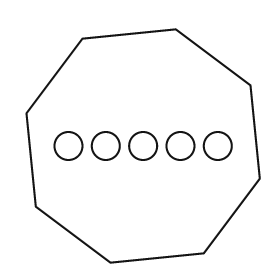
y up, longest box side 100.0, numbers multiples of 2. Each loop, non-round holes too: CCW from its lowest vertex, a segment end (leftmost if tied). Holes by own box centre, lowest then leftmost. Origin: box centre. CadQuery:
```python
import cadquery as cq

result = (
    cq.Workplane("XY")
    .moveTo(-14.0, -50.0)
    .lineTo(26.0, -46.0)
    .lineTo(50.0, -14.0)
    .lineTo(46.0, 26.0)
    .lineTo(14.0, 50.0)
    .lineTo(-26.0, 46.0)
    .lineTo(-50.0, 14.0)
    .lineTo(-46.0, -26.0)
    .close()
    .moveTo(-32.0, 0.0)
    .circle(6.0)
    .moveTo(-16.0, 0.0)
    .circle(6.0)
    .moveTo(0.0, 0.0)
    .circle(6.0)
    .moveTo(16.0, 0.0)
    .circle(6.0)
    .moveTo(32.0, 0.0)
    .circle(6.0)
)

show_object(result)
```